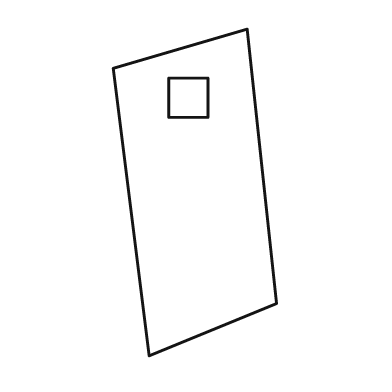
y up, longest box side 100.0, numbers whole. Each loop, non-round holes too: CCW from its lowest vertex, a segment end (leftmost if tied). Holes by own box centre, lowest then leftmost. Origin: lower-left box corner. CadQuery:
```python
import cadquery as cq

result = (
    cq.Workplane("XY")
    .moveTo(11.0, 0.0)
    .lineTo(50.0, 16.0)
    .lineTo(41.0, 100.0)
    .lineTo(0.0, 88.0)
    .close()
    .moveTo(17.0, 73.0)
    .lineTo(29.0, 73.0)
    .lineTo(29.0, 85.0)
    .lineTo(17.0, 85.0)
    .close()
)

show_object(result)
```